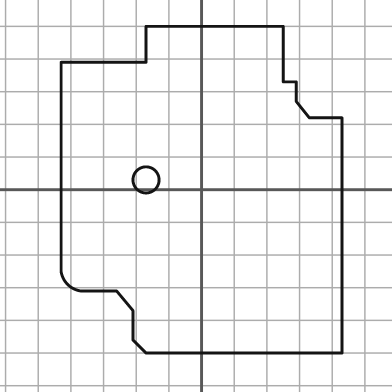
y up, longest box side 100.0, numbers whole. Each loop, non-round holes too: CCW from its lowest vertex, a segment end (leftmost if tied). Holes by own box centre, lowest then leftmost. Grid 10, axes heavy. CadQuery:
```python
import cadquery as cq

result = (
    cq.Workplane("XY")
    .moveTo(-17.0, -50.0)
    .lineTo(43.0, -50.0)
    .lineTo(43.0, 22.0)
    .lineTo(33.0, 22.0)
    .lineTo(29.0, 27.0)
    .lineTo(29.0, 33.0)
    .lineTo(25.0, 33.0)
    .lineTo(25.0, 50.0)
    .lineTo(-17.0, 50.0)
    .lineTo(-17.0, 39.0)
    .lineTo(-43.0, 39.0)
    .lineTo(-43.0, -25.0)
    .threePointArc((-41.0, -29.0), (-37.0, -31.0))
    .lineTo(-26.0, -31.0)
    .lineTo(-21.0, -37.0)
    .lineTo(-21.0, -46.0)
    .close()
    .moveTo(-17.0, 3.0)
    .circle(4.0)
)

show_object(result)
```